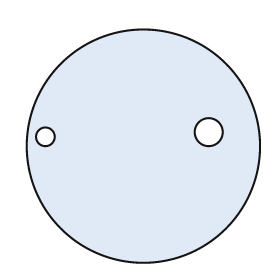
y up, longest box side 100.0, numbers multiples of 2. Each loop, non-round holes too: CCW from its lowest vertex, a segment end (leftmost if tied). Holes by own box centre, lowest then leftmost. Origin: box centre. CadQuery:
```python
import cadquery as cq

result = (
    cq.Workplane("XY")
    .moveTo(0.0, 0.0)
    .circle(50.0)
    .moveTo(-42.0, 4.0)
    .circle(4.0)
    .moveTo(28.0, 6.0)
    .circle(6.0)
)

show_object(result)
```